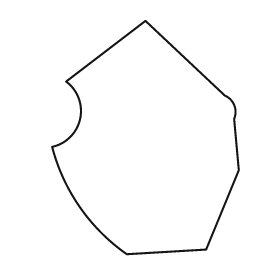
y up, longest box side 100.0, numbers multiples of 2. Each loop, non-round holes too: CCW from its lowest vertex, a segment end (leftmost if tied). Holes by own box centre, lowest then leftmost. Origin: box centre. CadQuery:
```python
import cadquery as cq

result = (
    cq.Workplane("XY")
    .moveTo(-8.0, -50.0)
    .lineTo(26.0, -48.0)
    .lineTo(40.0, -14.0)
    .lineTo(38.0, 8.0)
    .threePointArc((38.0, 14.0), (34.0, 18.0))
    .lineTo(0.0, 50.0)
    .lineTo(-34.0, 24.0)
    .threePointArc((-28.0, 8.0), (-40.0, -4.0))
    .threePointArc((-28.0, -30.0), (-8.0, -50.0))
    .close()
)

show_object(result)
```